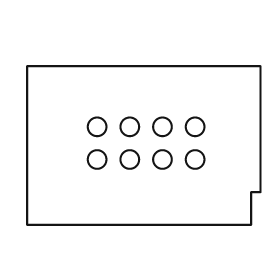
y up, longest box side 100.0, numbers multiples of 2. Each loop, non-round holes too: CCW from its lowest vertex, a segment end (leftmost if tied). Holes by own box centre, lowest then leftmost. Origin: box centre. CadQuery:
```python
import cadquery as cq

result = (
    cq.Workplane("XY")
    .moveTo(-50.0, -34.0)
    .lineTo(46.0, -34.0)
    .lineTo(46.0, -20.0)
    .lineTo(50.0, -20.0)
    .lineTo(50.0, 34.0)
    .lineTo(-50.0, 34.0)
    .close()
    .moveTo(-20.0, -6.0)
    .circle(4.0)
    .moveTo(-6.0, -6.0)
    .circle(4.0)
    .moveTo(8.0, -6.0)
    .circle(4.0)
    .moveTo(22.0, -6.0)
    .circle(4.0)
    .moveTo(-20.0, 8.0)
    .circle(4.0)
    .moveTo(-6.0, 8.0)
    .circle(4.0)
    .moveTo(8.0, 8.0)
    .circle(4.0)
    .moveTo(22.0, 8.0)
    .circle(4.0)
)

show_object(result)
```